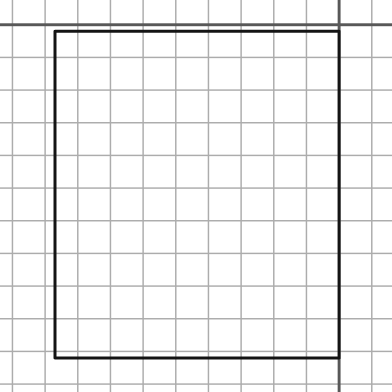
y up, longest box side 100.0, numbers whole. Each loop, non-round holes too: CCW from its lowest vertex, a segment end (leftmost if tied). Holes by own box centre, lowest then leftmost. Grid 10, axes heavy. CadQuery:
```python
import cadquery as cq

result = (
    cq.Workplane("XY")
    .moveTo(-87.0, -102.0)
    .lineTo(0.0, -102.0)
    .lineTo(0.0, -2.0)
    .lineTo(-87.0, -2.0)
    .close()
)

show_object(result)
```